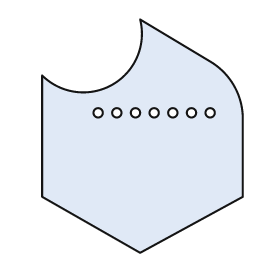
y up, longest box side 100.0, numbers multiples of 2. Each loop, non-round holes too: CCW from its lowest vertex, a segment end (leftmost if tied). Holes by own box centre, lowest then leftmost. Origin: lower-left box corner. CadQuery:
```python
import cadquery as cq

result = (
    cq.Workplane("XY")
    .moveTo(42.0, 0.0)
    .lineTo(86.0, 24.0)
    .lineTo(86.0, 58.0)
    .threePointArc((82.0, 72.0), (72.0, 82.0))
    .lineTo(42.0, 100.0)
    .threePointArc((30.0, 72.0), (0.0, 76.0))
    .lineTo(0.0, 24.0)
    .close()
    .moveTo(24.0, 60.0)
    .circle(2.0)
    .moveTo(32.0, 60.0)
    .circle(2.0)
    .moveTo(40.0, 60.0)
    .circle(2.0)
    .moveTo(48.0, 60.0)
    .circle(2.0)
    .moveTo(56.0, 60.0)
    .circle(2.0)
    .moveTo(64.0, 60.0)
    .circle(2.0)
    .moveTo(72.0, 60.0)
    .circle(2.0)
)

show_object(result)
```